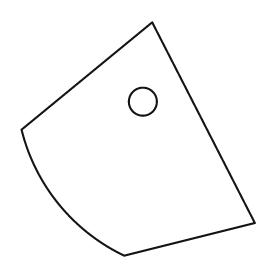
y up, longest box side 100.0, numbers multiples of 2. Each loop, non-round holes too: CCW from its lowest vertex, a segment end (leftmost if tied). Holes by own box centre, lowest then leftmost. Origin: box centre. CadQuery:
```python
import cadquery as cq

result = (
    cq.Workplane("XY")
    .moveTo(-6.0, -50.0)
    .lineTo(50.0, -36.0)
    .lineTo(6.0, 50.0)
    .lineTo(-50.0, 4.0)
    .threePointArc((-34.0, -28.0), (-6.0, -50.0))
    .close()
    .moveTo(2.0, 16.0)
    .circle(6.0)
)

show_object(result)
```